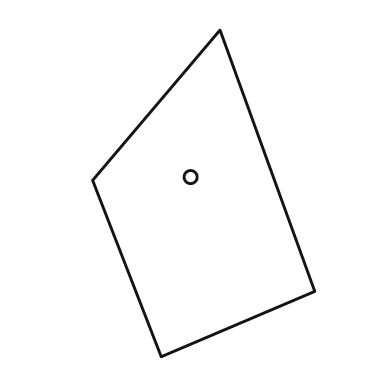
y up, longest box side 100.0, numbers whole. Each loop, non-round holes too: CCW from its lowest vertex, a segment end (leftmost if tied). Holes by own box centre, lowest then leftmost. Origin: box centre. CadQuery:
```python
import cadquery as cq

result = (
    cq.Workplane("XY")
    .moveTo(-13.0, -50.0)
    .lineTo(34.0, -30.0)
    .lineTo(5.0, 50.0)
    .lineTo(-34.0, 4.0)
    .close()
    .moveTo(-4.0, 5.0)
    .circle(2.0)
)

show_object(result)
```